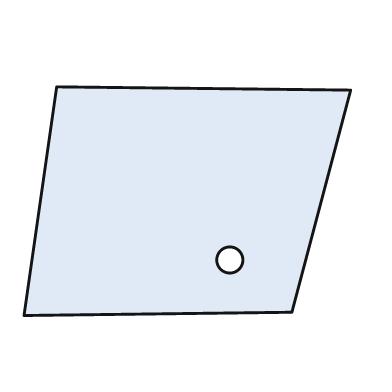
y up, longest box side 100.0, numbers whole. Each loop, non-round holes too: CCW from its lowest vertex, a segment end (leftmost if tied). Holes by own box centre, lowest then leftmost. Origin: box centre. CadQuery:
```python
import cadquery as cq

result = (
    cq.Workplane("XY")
    .moveTo(-50.0, -35.0)
    .lineTo(32.0, -34.0)
    .lineTo(50.0, 34.0)
    .lineTo(-40.0, 35.0)
    .close()
    .moveTo(13.0, -18.0)
    .circle(4.0)
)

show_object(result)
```